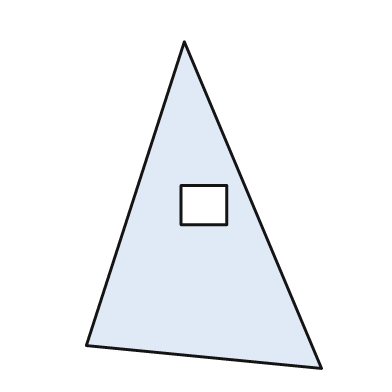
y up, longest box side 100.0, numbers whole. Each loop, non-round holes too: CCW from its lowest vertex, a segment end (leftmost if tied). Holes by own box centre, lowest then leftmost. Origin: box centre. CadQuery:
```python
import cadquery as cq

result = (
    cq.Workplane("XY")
    .moveTo(36.0, -50.0)
    .lineTo(-6.0, 50.0)
    .lineTo(-36.0, -43.0)
    .close()
    .moveTo(-7.0, -6.0)
    .lineTo(7.0, -6.0)
    .lineTo(7.0, 6.0)
    .lineTo(-7.0, 6.0)
    .close()
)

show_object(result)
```